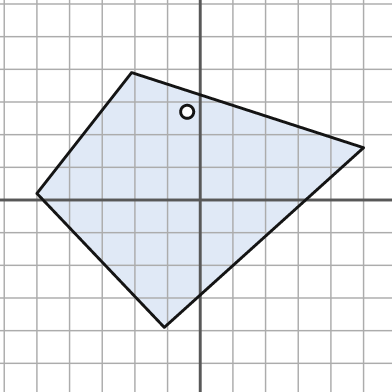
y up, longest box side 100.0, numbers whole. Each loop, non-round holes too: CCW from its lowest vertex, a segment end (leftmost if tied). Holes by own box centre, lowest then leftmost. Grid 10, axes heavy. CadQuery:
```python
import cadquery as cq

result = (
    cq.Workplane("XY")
    .moveTo(-11.0, -39.0)
    .lineTo(50.0, 16.0)
    .lineTo(-21.0, 39.0)
    .lineTo(-50.0, 2.0)
    .close()
    .moveTo(-4.0, 27.0)
    .circle(2.0)
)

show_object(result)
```